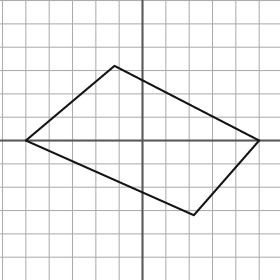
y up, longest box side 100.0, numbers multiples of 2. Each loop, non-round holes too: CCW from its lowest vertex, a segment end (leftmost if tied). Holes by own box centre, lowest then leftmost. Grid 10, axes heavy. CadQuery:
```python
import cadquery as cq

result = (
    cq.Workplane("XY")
    .moveTo(22.0, -32.0)
    .lineTo(50.0, 0.0)
    .lineTo(-12.0, 32.0)
    .lineTo(-50.0, 0.0)
    .close()
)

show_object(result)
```